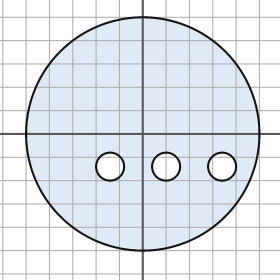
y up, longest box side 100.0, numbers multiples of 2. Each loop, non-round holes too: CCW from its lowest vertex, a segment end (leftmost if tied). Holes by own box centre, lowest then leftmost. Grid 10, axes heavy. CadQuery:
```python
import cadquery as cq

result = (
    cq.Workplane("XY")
    .moveTo(0.0, 0.0)
    .circle(50.0)
    .moveTo(-14.0, -14.0)
    .circle(6.0)
    .moveTo(10.0, -14.0)
    .circle(6.0)
    .moveTo(34.0, -14.0)
    .circle(6.0)
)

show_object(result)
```